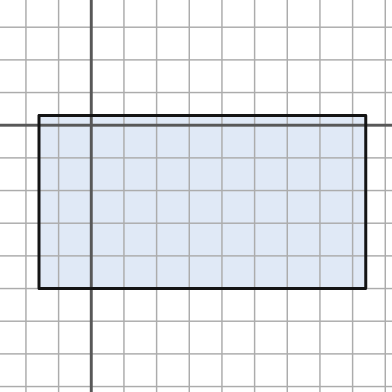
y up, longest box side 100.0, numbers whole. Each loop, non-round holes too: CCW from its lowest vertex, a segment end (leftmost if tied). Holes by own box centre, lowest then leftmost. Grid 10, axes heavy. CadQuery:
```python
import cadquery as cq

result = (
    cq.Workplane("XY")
    .moveTo(-16.0, -50.0)
    .lineTo(84.0, -50.0)
    .lineTo(84.0, 3.0)
    .lineTo(-16.0, 3.0)
    .close()
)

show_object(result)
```